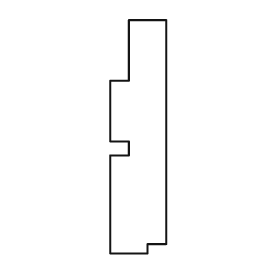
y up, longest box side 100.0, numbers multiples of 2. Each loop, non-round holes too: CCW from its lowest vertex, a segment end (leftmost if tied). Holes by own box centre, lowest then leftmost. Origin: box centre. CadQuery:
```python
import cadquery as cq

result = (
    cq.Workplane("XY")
    .moveTo(-12.0, -50.0)
    .lineTo(4.0, -50.0)
    .lineTo(4.0, -46.0)
    .lineTo(12.0, -46.0)
    .lineTo(12.0, 50.0)
    .lineTo(-4.0, 50.0)
    .lineTo(-4.0, 24.0)
    .lineTo(-12.0, 24.0)
    .lineTo(-12.0, -2.0)
    .lineTo(-4.0, -2.0)
    .lineTo(-4.0, -8.0)
    .lineTo(-12.0, -8.0)
    .close()
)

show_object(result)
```